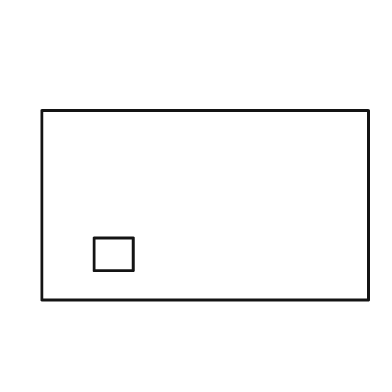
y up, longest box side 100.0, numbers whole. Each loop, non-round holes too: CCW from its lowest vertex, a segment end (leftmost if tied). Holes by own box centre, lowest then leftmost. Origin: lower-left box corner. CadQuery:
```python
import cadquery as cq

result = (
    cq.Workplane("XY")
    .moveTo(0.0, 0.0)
    .lineTo(100.0, 0.0)
    .lineTo(100.0, 58.0)
    .lineTo(0.0, 58.0)
    .close()
    .moveTo(16.0, 9.0)
    .lineTo(28.0, 9.0)
    .lineTo(28.0, 19.0)
    .lineTo(16.0, 19.0)
    .close()
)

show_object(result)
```